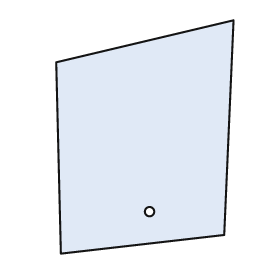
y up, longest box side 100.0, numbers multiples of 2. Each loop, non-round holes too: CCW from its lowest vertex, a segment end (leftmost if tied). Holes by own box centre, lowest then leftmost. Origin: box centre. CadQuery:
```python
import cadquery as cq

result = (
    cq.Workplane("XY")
    .moveTo(-36.0, -50.0)
    .lineTo(34.0, -42.0)
    .lineTo(38.0, 50.0)
    .lineTo(-38.0, 32.0)
    .close()
    .moveTo(2.0, -32.0)
    .circle(2.0)
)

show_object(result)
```